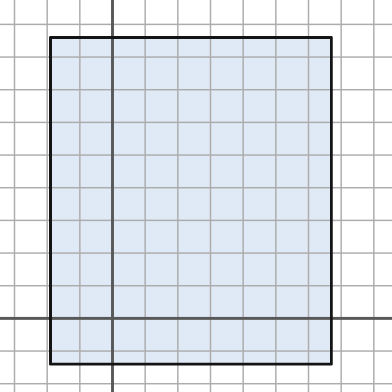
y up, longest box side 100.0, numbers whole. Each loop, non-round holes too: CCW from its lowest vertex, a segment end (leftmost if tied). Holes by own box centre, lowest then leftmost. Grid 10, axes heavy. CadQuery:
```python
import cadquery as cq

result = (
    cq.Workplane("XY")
    .moveTo(-19.0, -14.0)
    .lineTo(67.0, -14.0)
    .lineTo(67.0, 86.0)
    .lineTo(-19.0, 86.0)
    .close()
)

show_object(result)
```